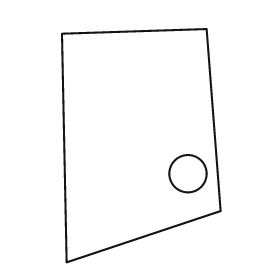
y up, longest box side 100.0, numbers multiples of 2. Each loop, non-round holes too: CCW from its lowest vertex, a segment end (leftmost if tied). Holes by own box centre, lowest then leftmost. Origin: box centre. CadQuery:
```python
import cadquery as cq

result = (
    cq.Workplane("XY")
    .moveTo(-32.0, -50.0)
    .lineTo(34.0, -28.0)
    .lineTo(28.0, 50.0)
    .lineTo(-34.0, 48.0)
    .close()
    .moveTo(20.0, -12.0)
    .circle(8.0)
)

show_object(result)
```